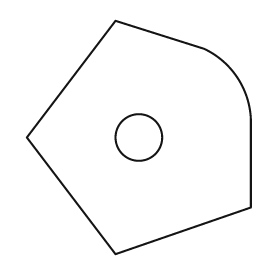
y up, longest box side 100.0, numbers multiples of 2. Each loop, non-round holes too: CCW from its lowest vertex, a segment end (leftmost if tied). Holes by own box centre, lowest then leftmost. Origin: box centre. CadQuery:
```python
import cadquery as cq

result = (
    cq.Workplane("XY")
    .moveTo(-10.0, -50.0)
    .lineTo(48.0, -30.0)
    .lineTo(48.0, 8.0)
    .threePointArc((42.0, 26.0), (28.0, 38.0))
    .lineTo(-10.0, 50.0)
    .lineTo(-48.0, 0.0)
    .close()
    .moveTo(0.0, 0.0)
    .circle(10.0)
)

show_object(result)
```